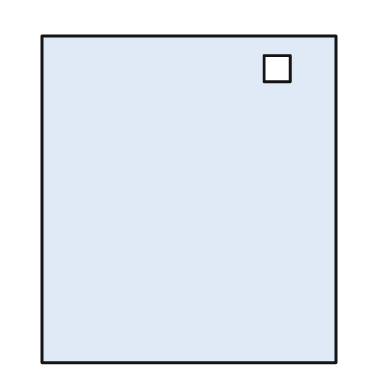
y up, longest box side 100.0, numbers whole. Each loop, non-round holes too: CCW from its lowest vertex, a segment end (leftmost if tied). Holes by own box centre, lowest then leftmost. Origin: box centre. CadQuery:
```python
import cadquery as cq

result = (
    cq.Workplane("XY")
    .moveTo(-45.0, -50.0)
    .lineTo(45.0, -50.0)
    .lineTo(45.0, 50.0)
    .lineTo(-45.0, 50.0)
    .close()
    .moveTo(23.0, 36.0)
    .lineTo(31.0, 36.0)
    .lineTo(31.0, 44.0)
    .lineTo(23.0, 44.0)
    .close()
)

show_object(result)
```